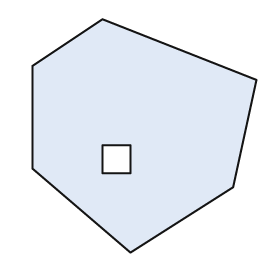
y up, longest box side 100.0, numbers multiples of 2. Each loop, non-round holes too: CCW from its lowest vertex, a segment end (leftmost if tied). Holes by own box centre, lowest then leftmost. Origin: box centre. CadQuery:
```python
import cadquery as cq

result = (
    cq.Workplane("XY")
    .moveTo(-6.0, -50.0)
    .lineTo(38.0, -22.0)
    .lineTo(48.0, 24.0)
    .lineTo(-18.0, 50.0)
    .lineTo(-48.0, 30.0)
    .lineTo(-48.0, -14.0)
    .close()
    .moveTo(-18.0, -16.0)
    .lineTo(-6.0, -16.0)
    .lineTo(-6.0, -4.0)
    .lineTo(-18.0, -4.0)
    .close()
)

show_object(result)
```